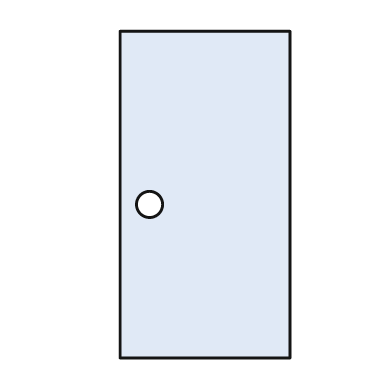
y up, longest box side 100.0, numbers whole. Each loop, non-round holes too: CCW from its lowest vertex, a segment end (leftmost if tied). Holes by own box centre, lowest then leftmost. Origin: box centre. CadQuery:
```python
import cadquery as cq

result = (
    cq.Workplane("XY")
    .moveTo(-26.0, -50.0)
    .lineTo(26.0, -50.0)
    .lineTo(26.0, 50.0)
    .lineTo(-26.0, 50.0)
    .close()
    .moveTo(-17.0, -3.0)
    .circle(4.0)
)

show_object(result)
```